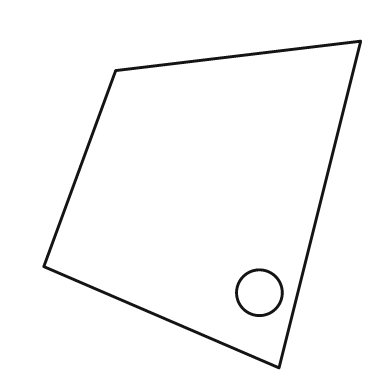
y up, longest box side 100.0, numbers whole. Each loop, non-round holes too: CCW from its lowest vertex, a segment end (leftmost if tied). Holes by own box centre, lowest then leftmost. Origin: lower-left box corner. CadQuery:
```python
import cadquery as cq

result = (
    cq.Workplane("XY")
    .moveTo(72.0, 0.0)
    .lineTo(97.0, 100.0)
    .lineTo(22.0, 91.0)
    .lineTo(0.0, 31.0)
    .close()
    .moveTo(66.0, 23.0)
    .circle(7.0)
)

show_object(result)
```